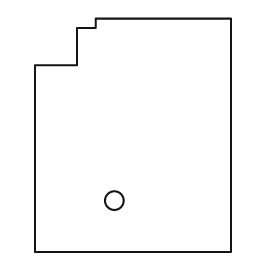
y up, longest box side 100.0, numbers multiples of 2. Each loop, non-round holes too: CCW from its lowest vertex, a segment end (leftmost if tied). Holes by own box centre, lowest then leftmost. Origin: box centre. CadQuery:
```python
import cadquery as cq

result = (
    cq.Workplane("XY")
    .moveTo(-42.0, -50.0)
    .lineTo(42.0, -50.0)
    .lineTo(42.0, 50.0)
    .lineTo(-16.0, 50.0)
    .lineTo(-16.0, 46.0)
    .lineTo(-24.0, 46.0)
    .lineTo(-24.0, 30.0)
    .lineTo(-42.0, 30.0)
    .close()
    .moveTo(-8.0, -28.0)
    .circle(4.0)
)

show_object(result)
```